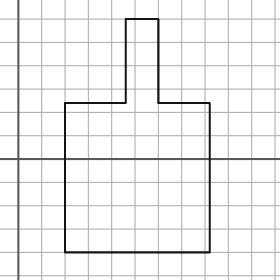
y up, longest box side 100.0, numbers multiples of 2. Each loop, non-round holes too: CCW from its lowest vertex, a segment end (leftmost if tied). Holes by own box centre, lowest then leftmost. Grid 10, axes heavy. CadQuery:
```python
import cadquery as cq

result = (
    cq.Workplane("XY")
    .moveTo(20.0, -40.0)
    .lineTo(82.0, -40.0)
    .lineTo(82.0, 24.0)
    .lineTo(60.0, 24.0)
    .lineTo(60.0, 60.0)
    .lineTo(46.0, 60.0)
    .lineTo(46.0, 24.0)
    .lineTo(20.0, 24.0)
    .close()
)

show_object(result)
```